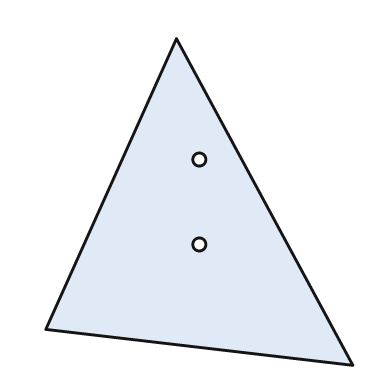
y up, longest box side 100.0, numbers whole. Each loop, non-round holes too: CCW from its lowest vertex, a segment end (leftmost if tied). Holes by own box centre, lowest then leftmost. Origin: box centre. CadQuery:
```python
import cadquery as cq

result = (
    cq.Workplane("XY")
    .moveTo(47.0, -50.0)
    .lineTo(-7.0, 50.0)
    .lineTo(-47.0, -39.0)
    .close()
    .moveTo(0.0, -13.0)
    .circle(2.0)
    .moveTo(0.0, 13.0)
    .circle(2.0)
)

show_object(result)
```